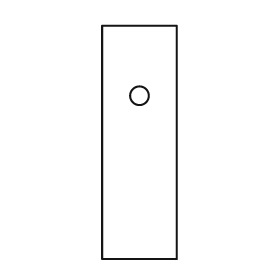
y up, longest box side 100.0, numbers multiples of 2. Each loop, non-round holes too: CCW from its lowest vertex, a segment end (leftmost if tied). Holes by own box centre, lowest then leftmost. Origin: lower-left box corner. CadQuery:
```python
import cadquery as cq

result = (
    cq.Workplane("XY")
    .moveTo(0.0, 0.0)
    .lineTo(32.0, 0.0)
    .lineTo(32.0, 100.0)
    .lineTo(0.0, 100.0)
    .close()
    .moveTo(16.0, 70.0)
    .circle(4.0)
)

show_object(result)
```